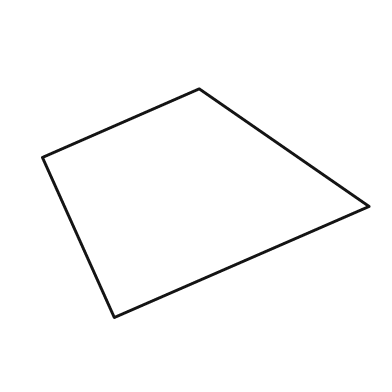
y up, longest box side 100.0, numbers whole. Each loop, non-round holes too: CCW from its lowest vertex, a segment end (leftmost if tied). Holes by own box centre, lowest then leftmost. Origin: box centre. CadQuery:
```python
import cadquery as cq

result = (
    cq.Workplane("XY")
    .moveTo(-28.0, -35.0)
    .lineTo(50.0, -1.0)
    .lineTo(-2.0, 35.0)
    .lineTo(-50.0, 14.0)
    .close()
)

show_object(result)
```